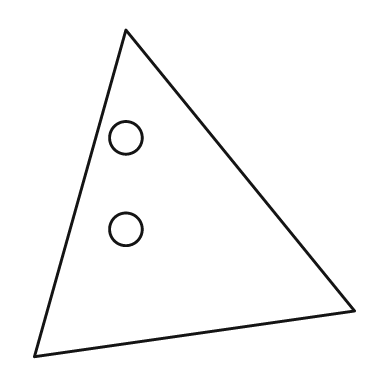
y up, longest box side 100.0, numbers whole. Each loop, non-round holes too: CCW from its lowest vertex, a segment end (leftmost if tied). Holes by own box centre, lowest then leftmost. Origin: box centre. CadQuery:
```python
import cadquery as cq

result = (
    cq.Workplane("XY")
    .moveTo(-49.0, -50.0)
    .lineTo(49.0, -36.0)
    .lineTo(-21.0, 50.0)
    .close()
    .moveTo(-21.0, -11.0)
    .circle(5.0)
    .moveTo(-21.0, 17.0)
    .circle(5.0)
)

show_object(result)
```